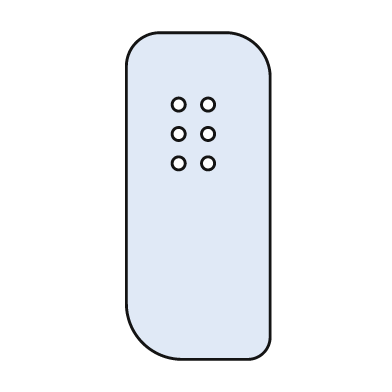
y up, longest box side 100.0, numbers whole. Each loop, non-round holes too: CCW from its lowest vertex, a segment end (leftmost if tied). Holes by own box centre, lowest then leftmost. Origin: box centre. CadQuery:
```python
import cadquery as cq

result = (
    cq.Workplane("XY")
    .moveTo(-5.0, -50.0)
    .lineTo(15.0, -50.0)
    .threePointArc((20.0, -48.0), (22.0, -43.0))
    .lineTo(22.0, 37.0)
    .threePointArc((18.0, 46.0), (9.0, 50.0))
    .lineTo(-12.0, 50.0)
    .threePointArc((-19.0, 47.0), (-22.0, 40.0))
    .lineTo(-22.0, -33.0)
    .threePointArc((-17.0, -45.0), (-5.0, -50.0))
    .close()
    .moveTo(-6.0, 10.0)
    .circle(2.0)
    .moveTo(3.0, 10.0)
    .circle(2.0)
    .moveTo(-6.0, 19.0)
    .circle(2.0)
    .moveTo(3.0, 19.0)
    .circle(2.0)
    .moveTo(-6.0, 28.0)
    .circle(2.0)
    .moveTo(3.0, 28.0)
    .circle(2.0)
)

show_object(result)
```